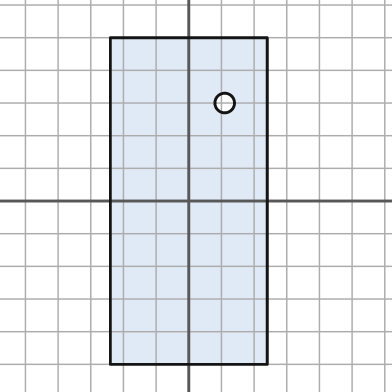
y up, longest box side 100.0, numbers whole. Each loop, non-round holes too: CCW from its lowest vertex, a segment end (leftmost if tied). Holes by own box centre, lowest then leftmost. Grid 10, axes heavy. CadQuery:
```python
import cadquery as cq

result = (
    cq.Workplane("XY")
    .moveTo(-24.0, -50.0)
    .lineTo(24.0, -50.0)
    .lineTo(24.0, 50.0)
    .lineTo(-24.0, 50.0)
    .close()
    .moveTo(11.0, 30.0)
    .circle(3.0)
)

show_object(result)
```